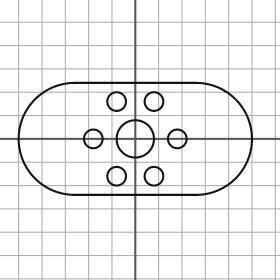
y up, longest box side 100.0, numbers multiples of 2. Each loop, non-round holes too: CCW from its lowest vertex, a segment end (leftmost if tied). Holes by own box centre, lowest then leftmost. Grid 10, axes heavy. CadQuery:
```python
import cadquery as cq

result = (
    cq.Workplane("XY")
    .moveTo(-26.0, -24.0)
    .lineTo(26.0, -24.0)
    .threePointArc((50.0, 0.0), (26.0, 24.0))
    .lineTo(-26.0, 24.0)
    .threePointArc((-50.0, 0.0), (-26.0, -24.0))
    .close()
    .moveTo(-8.0, -16.0)
    .circle(4.0)
    .moveTo(8.0, -16.0)
    .circle(4.0)
    .moveTo(-18.0, 0.0)
    .circle(4.0)
    .moveTo(0.0, 0.0)
    .circle(8.0)
    .moveTo(18.0, 0.0)
    .circle(4.0)
    .moveTo(-8.0, 16.0)
    .circle(4.0)
    .moveTo(8.0, 16.0)
    .circle(4.0)
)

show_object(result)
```